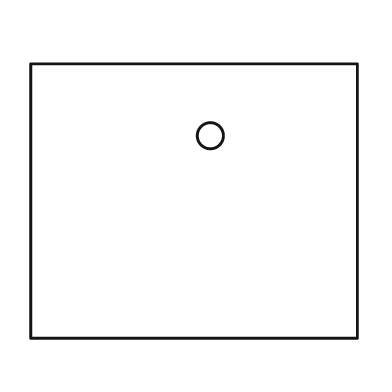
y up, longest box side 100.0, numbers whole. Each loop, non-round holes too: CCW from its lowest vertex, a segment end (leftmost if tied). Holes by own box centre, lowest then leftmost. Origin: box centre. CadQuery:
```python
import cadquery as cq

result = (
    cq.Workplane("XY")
    .moveTo(-50.0, -42.0)
    .lineTo(50.0, -42.0)
    .lineTo(50.0, 42.0)
    .lineTo(-50.0, 42.0)
    .close()
    .moveTo(5.0, 20.0)
    .circle(4.0)
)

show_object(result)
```